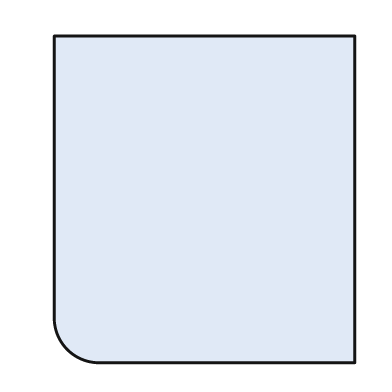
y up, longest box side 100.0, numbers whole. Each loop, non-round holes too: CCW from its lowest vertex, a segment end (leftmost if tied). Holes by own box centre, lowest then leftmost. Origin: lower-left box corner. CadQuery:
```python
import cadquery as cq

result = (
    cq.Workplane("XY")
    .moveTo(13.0, 0.0)
    .lineTo(92.0, 0.0)
    .lineTo(92.0, 100.0)
    .lineTo(0.0, 100.0)
    .lineTo(0.0, 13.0)
    .threePointArc((4.0, 4.0), (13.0, 0.0))
    .close()
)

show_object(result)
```